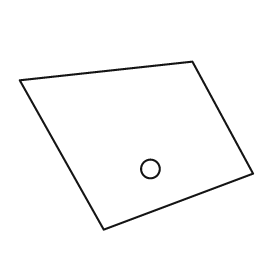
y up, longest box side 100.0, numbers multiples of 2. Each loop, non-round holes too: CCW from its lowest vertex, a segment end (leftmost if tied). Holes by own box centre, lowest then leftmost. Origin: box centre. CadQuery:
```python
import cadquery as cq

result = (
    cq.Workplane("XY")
    .moveTo(-14.0, -36.0)
    .lineTo(50.0, -12.0)
    .lineTo(24.0, 36.0)
    .lineTo(-50.0, 28.0)
    .close()
    .moveTo(6.0, -10.0)
    .circle(4.0)
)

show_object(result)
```